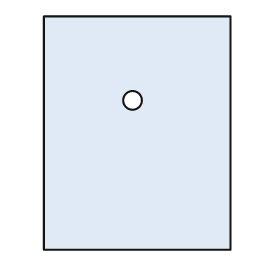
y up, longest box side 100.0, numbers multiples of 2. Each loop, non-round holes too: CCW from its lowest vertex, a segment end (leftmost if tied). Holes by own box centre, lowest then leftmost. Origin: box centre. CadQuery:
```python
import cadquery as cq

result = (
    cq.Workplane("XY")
    .moveTo(-40.0, -50.0)
    .lineTo(40.0, -50.0)
    .lineTo(40.0, 50.0)
    .lineTo(-40.0, 50.0)
    .close()
    .moveTo(-2.0, 14.0)
    .circle(4.0)
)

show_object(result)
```